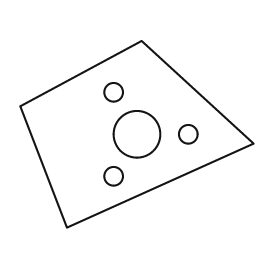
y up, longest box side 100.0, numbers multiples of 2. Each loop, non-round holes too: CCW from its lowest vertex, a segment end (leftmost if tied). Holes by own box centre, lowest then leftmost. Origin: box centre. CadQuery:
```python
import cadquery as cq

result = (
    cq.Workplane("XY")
    .moveTo(-30.0, -40.0)
    .lineTo(50.0, -4.0)
    .lineTo(2.0, 40.0)
    .lineTo(-50.0, 12.0)
    .close()
    .moveTo(-10.0, -18.0)
    .circle(4.0)
    .moveTo(0.0, 0.0)
    .circle(10.0)
    .moveTo(22.0, 0.0)
    .circle(4.0)
    .moveTo(-10.0, 18.0)
    .circle(4.0)
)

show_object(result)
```